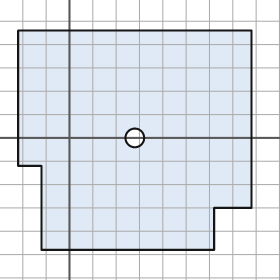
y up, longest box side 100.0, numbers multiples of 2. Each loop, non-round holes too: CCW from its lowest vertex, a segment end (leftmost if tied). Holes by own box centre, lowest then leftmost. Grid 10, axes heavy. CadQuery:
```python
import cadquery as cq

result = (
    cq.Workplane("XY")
    .moveTo(-12.0, -48.0)
    .lineTo(62.0, -48.0)
    .lineTo(62.0, -30.0)
    .lineTo(78.0, -30.0)
    .lineTo(78.0, 46.0)
    .lineTo(-22.0, 46.0)
    .lineTo(-22.0, -12.0)
    .lineTo(-12.0, -12.0)
    .close()
    .moveTo(28.0, 0.0)
    .circle(4.0)
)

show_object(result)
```